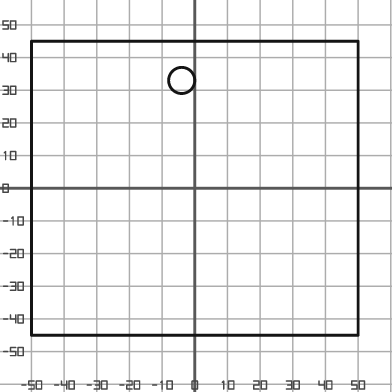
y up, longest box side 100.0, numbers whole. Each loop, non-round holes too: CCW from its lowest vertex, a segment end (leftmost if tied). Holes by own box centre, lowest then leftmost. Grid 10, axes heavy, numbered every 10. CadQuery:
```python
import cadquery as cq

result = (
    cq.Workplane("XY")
    .moveTo(-50.0, -45.0)
    .lineTo(50.0, -45.0)
    .lineTo(50.0, 45.0)
    .lineTo(-50.0, 45.0)
    .close()
    .moveTo(-4.0, 33.0)
    .circle(4.0)
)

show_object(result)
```